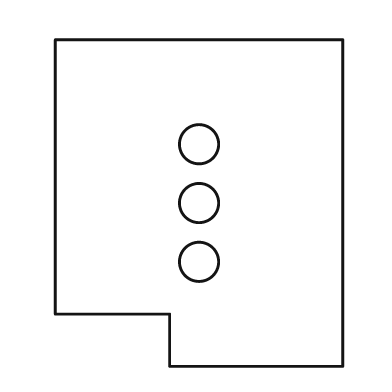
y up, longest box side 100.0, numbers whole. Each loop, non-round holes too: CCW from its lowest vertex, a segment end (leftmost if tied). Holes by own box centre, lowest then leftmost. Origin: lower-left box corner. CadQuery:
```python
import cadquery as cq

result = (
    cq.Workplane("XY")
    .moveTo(35.0, 0.0)
    .lineTo(88.0, 0.0)
    .lineTo(88.0, 100.0)
    .lineTo(0.0, 100.0)
    .lineTo(0.0, 16.0)
    .lineTo(35.0, 16.0)
    .close()
    .moveTo(44.0, 32.0)
    .circle(6.0)
    .moveTo(44.0, 50.0)
    .circle(6.0)
    .moveTo(44.0, 68.0)
    .circle(6.0)
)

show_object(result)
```